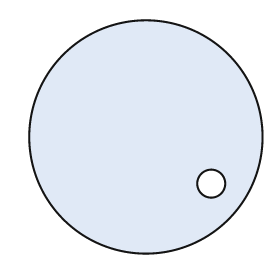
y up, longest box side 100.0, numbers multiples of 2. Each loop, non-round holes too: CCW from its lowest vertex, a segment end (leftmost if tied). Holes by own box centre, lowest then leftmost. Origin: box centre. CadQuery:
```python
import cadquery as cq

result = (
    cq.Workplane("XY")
    .moveTo(0.0, 0.0)
    .circle(50.0)
    .moveTo(28.0, -20.0)
    .circle(6.0)
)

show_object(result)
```